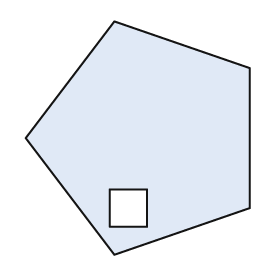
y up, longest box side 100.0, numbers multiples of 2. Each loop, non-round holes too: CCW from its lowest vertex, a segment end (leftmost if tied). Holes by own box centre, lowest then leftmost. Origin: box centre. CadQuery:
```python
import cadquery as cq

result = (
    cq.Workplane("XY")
    .moveTo(-10.0, -50.0)
    .lineTo(48.0, -30.0)
    .lineTo(48.0, 30.0)
    .lineTo(-10.0, 50.0)
    .lineTo(-48.0, 0.0)
    .close()
    .moveTo(-12.0, -38.0)
    .lineTo(4.0, -38.0)
    .lineTo(4.0, -22.0)
    .lineTo(-12.0, -22.0)
    .close()
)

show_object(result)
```